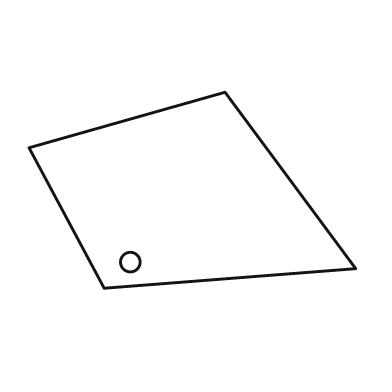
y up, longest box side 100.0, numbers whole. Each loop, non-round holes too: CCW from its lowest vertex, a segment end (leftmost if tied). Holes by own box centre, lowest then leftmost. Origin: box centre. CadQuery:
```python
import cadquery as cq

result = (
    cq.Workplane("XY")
    .moveTo(-27.0, -30.0)
    .lineTo(50.0, -24.0)
    .lineTo(10.0, 30.0)
    .lineTo(-50.0, 13.0)
    .close()
    .moveTo(-19.0, -22.0)
    .circle(3.0)
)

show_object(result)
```